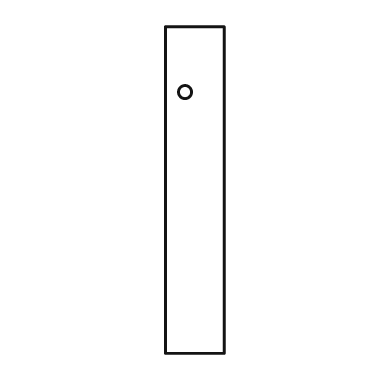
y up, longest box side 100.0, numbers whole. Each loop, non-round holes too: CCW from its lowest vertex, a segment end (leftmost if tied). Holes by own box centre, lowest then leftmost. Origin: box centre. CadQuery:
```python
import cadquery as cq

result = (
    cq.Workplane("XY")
    .moveTo(-9.0, -50.0)
    .lineTo(9.0, -50.0)
    .lineTo(9.0, 50.0)
    .lineTo(-9.0, 50.0)
    .close()
    .moveTo(-3.0, 30.0)
    .circle(2.0)
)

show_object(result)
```